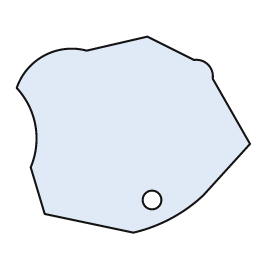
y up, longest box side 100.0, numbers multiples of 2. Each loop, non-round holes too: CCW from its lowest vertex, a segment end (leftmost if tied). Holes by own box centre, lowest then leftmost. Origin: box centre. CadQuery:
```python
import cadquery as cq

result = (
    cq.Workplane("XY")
    .moveTo(0.0, -42.0)
    .threePointArc((16.0, -36.0), (30.0, -26.0))
    .lineTo(50.0, -4.0)
    .lineTo(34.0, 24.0)
    .threePointArc((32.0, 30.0), (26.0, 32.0))
    .lineTo(6.0, 42.0)
    .lineTo(-20.0, 36.0)
    .threePointArc((-38.0, 34.0), (-50.0, 20.0))
    .threePointArc((-42.0, 4.0), (-44.0, -14.0))
    .lineTo(-38.0, -34.0)
    .close()
    .moveTo(8.0, -28.0)
    .circle(4.0)
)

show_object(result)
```